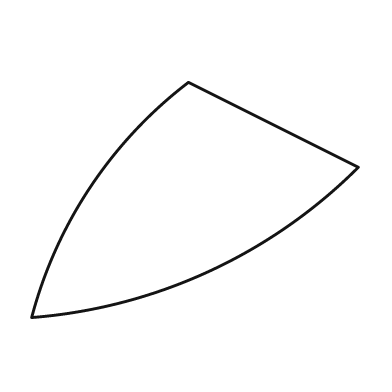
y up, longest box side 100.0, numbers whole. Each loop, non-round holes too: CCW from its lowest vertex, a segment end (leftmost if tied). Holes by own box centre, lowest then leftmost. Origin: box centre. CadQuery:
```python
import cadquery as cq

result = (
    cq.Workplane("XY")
    .moveTo(-50.0, -36.0)
    .threePointArc((4.0, -22.0), (50.0, 10.0))
    .lineTo(-2.0, 36.0)
    .threePointArc((-32.0, 4.0), (-50.0, -36.0))
    .close()
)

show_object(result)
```